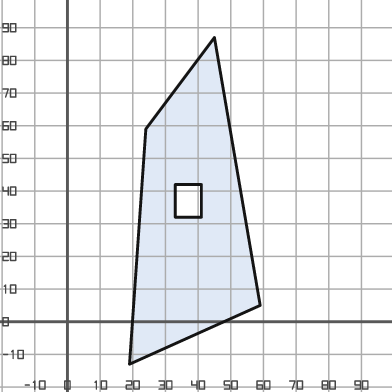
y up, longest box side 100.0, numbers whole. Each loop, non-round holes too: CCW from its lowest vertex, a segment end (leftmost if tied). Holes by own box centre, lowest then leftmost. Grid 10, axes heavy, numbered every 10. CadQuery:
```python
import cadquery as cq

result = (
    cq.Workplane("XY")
    .moveTo(19.0, -13.0)
    .lineTo(59.0, 5.0)
    .lineTo(45.0, 87.0)
    .lineTo(24.0, 59.0)
    .close()
    .moveTo(33.0, 32.0)
    .lineTo(41.0, 32.0)
    .lineTo(41.0, 42.0)
    .lineTo(33.0, 42.0)
    .close()
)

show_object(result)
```